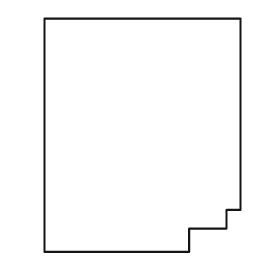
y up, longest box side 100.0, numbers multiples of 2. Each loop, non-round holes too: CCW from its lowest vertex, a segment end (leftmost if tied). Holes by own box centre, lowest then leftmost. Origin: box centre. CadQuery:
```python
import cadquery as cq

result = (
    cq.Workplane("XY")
    .moveTo(-42.0, -50.0)
    .lineTo(20.0, -50.0)
    .lineTo(20.0, -40.0)
    .lineTo(36.0, -40.0)
    .lineTo(36.0, -32.0)
    .lineTo(42.0, -32.0)
    .lineTo(42.0, 50.0)
    .lineTo(-42.0, 50.0)
    .close()
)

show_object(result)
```